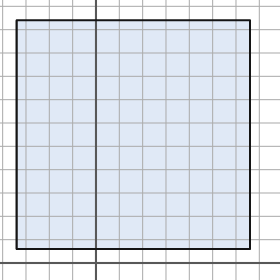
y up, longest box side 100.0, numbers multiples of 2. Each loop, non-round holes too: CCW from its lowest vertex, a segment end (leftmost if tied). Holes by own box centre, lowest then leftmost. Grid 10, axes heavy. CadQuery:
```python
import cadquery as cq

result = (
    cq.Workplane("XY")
    .moveTo(-34.0, 6.0)
    .lineTo(66.0, 6.0)
    .lineTo(66.0, 104.0)
    .lineTo(-34.0, 104.0)
    .close()
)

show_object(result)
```